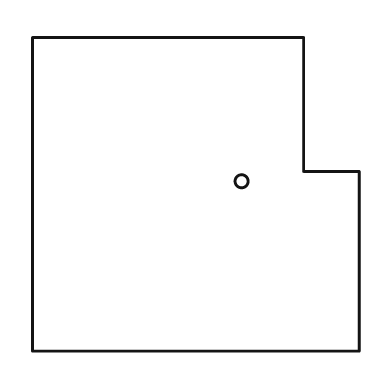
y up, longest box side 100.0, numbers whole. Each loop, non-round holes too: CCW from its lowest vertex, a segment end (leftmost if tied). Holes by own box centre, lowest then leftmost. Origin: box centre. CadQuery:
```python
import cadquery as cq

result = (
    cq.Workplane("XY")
    .moveTo(-50.0, -48.0)
    .lineTo(50.0, -48.0)
    .lineTo(50.0, 7.0)
    .lineTo(33.0, 7.0)
    .lineTo(33.0, 48.0)
    .lineTo(-50.0, 48.0)
    .close()
    .moveTo(14.0, 4.0)
    .circle(2.0)
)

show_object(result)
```